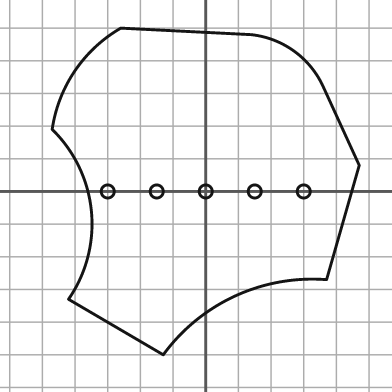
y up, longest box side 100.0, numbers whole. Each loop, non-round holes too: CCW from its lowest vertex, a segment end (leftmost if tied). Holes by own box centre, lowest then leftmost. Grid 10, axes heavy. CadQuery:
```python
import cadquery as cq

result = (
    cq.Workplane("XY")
    .moveTo(-13.0, -50.0)
    .threePointArc((9.0, -32.0), (37.0, -27.0))
    .lineTo(47.0, 8.0)
    .lineTo(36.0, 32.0)
    .threePointArc((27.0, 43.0), (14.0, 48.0))
    .lineTo(-26.0, 50.0)
    .threePointArc((-40.0, 37.0), (-47.0, 19.0))
    .threePointArc((-35.0, -6.0), (-42.0, -33.0))
    .close()
    .moveTo(-30.0, 0.0)
    .circle(2.0)
    .moveTo(-15.0, 0.0)
    .circle(2.0)
    .moveTo(0.0, 0.0)
    .circle(2.0)
    .moveTo(15.0, 0.0)
    .circle(2.0)
    .moveTo(30.0, 0.0)
    .circle(2.0)
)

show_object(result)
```